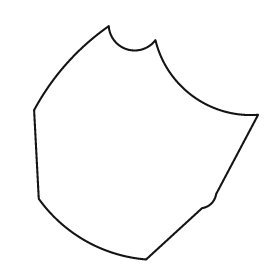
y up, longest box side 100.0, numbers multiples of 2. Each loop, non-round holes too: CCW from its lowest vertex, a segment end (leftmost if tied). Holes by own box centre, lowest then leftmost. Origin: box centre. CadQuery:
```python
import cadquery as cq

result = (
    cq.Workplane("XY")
    .moveTo(0.0, -50.0)
    .lineTo(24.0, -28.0)
    .threePointArc((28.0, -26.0), (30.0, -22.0))
    .lineTo(48.0, 12.0)
    .threePointArc((20.0, 20.0), (4.0, 44.0))
    .threePointArc((-8.0, 40.0), (-16.0, 50.0))
    .threePointArc((-34.0, 34.0), (-48.0, 14.0))
    .lineTo(-46.0, -24.0)
    .threePointArc((-26.0, -42.0), (0.0, -50.0))
    .close()
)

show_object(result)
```